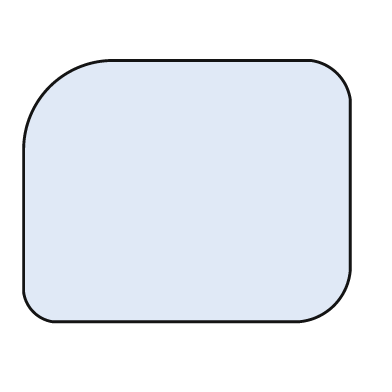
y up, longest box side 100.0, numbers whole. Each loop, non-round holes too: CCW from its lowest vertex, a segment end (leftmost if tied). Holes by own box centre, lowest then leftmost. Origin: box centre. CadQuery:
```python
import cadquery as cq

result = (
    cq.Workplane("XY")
    .moveTo(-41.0, -40.0)
    .lineTo(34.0, -40.0)
    .threePointArc((45.0, -35.0), (50.0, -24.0))
    .lineTo(50.0, 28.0)
    .threePointArc((46.0, 36.0), (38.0, 40.0))
    .lineTo(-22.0, 40.0)
    .threePointArc((-42.0, 32.0), (-50.0, 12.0))
    .lineTo(-50.0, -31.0)
    .threePointArc((-47.0, -37.0), (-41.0, -40.0))
    .close()
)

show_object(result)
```